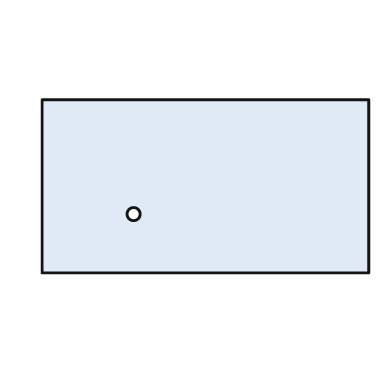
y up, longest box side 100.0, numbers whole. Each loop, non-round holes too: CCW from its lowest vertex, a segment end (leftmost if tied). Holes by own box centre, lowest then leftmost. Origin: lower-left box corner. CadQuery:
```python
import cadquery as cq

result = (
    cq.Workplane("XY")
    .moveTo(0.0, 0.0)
    .lineTo(100.0, 0.0)
    .lineTo(100.0, 53.0)
    .lineTo(0.0, 53.0)
    .close()
    .moveTo(28.0, 18.0)
    .circle(2.0)
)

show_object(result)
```